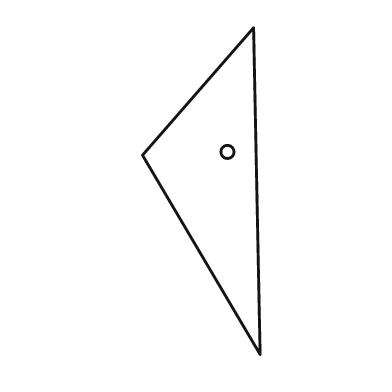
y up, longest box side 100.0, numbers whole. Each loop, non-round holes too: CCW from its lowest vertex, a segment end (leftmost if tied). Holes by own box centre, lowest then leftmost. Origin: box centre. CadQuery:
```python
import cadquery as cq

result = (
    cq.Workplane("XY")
    .moveTo(18.0, -50.0)
    .lineTo(16.0, 50.0)
    .lineTo(-18.0, 11.0)
    .close()
    .moveTo(8.0, 12.0)
    .circle(2.0)
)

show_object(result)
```